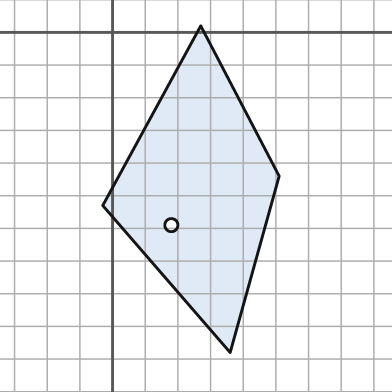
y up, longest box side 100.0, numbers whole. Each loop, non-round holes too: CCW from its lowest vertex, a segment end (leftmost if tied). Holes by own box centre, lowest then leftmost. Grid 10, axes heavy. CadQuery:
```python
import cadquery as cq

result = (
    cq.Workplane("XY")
    .moveTo(36.0, -98.0)
    .lineTo(51.0, -44.0)
    .lineTo(27.0, 2.0)
    .lineTo(-3.0, -53.0)
    .close()
    .moveTo(18.0, -59.0)
    .circle(2.0)
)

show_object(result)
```